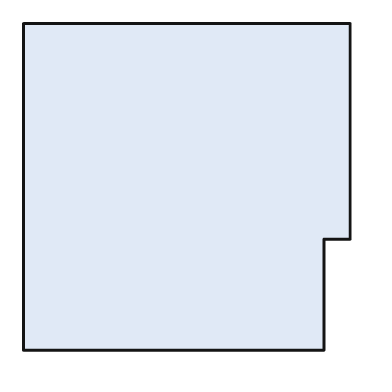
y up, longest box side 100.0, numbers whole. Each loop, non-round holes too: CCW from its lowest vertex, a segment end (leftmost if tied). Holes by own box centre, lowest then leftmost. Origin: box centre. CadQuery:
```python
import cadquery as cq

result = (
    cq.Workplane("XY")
    .moveTo(-50.0, -50.0)
    .lineTo(42.0, -50.0)
    .lineTo(42.0, -16.0)
    .lineTo(50.0, -16.0)
    .lineTo(50.0, 50.0)
    .lineTo(-50.0, 50.0)
    .close()
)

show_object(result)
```